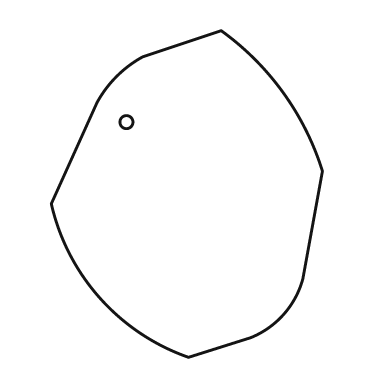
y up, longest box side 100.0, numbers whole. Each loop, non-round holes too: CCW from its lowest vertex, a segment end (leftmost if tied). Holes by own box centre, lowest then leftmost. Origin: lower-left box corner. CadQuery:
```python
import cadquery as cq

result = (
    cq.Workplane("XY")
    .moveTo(42.0, 0.0)
    .lineTo(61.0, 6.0)
    .threePointArc((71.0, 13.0), (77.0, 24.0))
    .lineTo(83.0, 57.0)
    .threePointArc((71.0, 81.0), (52.0, 100.0))
    .lineTo(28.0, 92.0)
    .threePointArc((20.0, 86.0), (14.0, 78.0))
    .lineTo(0.0, 47.0)
    .threePointArc((15.0, 18.0), (42.0, 0.0))
    .close()
    .moveTo(23.0, 72.0)
    .circle(2.0)
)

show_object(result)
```